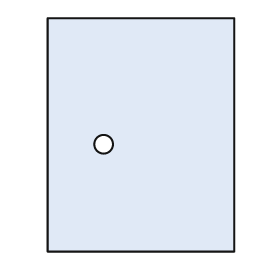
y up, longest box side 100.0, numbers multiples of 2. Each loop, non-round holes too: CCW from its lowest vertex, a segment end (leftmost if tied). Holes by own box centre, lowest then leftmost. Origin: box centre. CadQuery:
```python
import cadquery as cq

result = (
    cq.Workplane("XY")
    .moveTo(-40.0, -50.0)
    .lineTo(40.0, -50.0)
    .lineTo(40.0, 50.0)
    .lineTo(-40.0, 50.0)
    .close()
    .moveTo(-16.0, -4.0)
    .circle(4.0)
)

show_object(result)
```